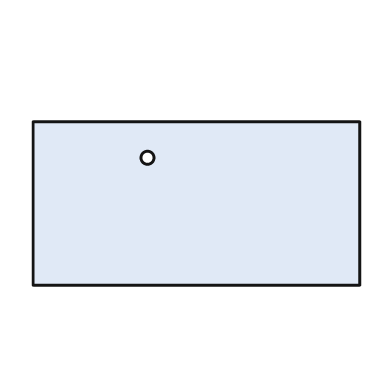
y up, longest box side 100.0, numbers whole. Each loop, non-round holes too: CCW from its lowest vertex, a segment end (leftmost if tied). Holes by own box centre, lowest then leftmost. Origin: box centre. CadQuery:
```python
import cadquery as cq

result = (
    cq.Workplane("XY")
    .moveTo(-50.0, -25.0)
    .lineTo(50.0, -25.0)
    .lineTo(50.0, 25.0)
    .lineTo(-50.0, 25.0)
    .close()
    .moveTo(-15.0, 14.0)
    .circle(2.0)
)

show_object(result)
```